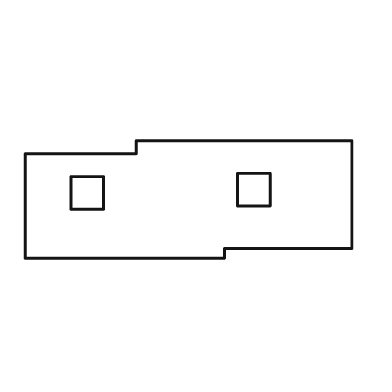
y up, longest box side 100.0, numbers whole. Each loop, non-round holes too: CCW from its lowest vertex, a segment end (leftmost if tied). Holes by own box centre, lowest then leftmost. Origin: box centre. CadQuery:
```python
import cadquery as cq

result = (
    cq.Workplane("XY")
    .moveTo(-50.0, -18.0)
    .lineTo(11.0, -18.0)
    .lineTo(11.0, -15.0)
    .lineTo(50.0, -15.0)
    .lineTo(50.0, 18.0)
    .lineTo(-16.0, 18.0)
    .lineTo(-16.0, 14.0)
    .lineTo(-50.0, 14.0)
    .close()
    .moveTo(-36.0, -3.0)
    .lineTo(-26.0, -3.0)
    .lineTo(-26.0, 7.0)
    .lineTo(-36.0, 7.0)
    .close()
    .moveTo(15.0, -2.0)
    .lineTo(25.0, -2.0)
    .lineTo(25.0, 8.0)
    .lineTo(15.0, 8.0)
    .close()
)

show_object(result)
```